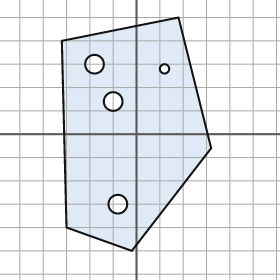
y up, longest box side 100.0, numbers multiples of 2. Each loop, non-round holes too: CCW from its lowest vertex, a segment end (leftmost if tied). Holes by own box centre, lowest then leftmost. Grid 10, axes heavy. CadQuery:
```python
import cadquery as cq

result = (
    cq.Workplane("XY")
    .moveTo(-2.0, -50.0)
    .lineTo(32.0, -6.0)
    .lineTo(18.0, 50.0)
    .lineTo(-32.0, 40.0)
    .lineTo(-30.0, -40.0)
    .close()
    .moveTo(-8.0, -30.0)
    .circle(4.0)
    .moveTo(-10.0, 14.0)
    .circle(4.0)
    .moveTo(12.0, 28.0)
    .circle(2.0)
    .moveTo(-18.0, 30.0)
    .circle(4.0)
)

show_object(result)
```